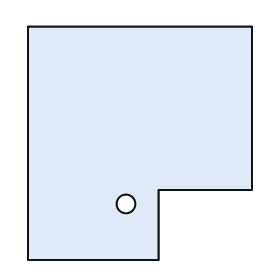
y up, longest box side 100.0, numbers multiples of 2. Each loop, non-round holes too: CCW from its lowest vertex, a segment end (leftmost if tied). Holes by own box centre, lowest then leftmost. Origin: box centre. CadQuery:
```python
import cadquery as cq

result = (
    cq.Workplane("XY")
    .moveTo(-48.0, -50.0)
    .lineTo(8.0, -50.0)
    .lineTo(8.0, -20.0)
    .lineTo(48.0, -20.0)
    .lineTo(48.0, 50.0)
    .lineTo(-48.0, 50.0)
    .close()
    .moveTo(-6.0, -26.0)
    .circle(4.0)
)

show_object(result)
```